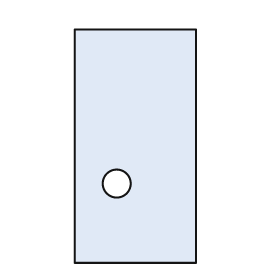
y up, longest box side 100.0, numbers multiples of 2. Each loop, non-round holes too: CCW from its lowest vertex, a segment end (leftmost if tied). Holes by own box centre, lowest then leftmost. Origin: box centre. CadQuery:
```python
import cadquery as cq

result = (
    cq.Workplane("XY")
    .moveTo(-26.0, -50.0)
    .lineTo(26.0, -50.0)
    .lineTo(26.0, 50.0)
    .lineTo(-26.0, 50.0)
    .close()
    .moveTo(-8.0, -16.0)
    .circle(6.0)
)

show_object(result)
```